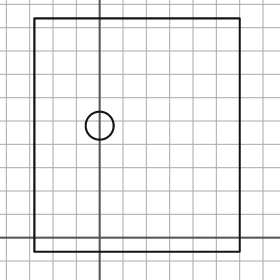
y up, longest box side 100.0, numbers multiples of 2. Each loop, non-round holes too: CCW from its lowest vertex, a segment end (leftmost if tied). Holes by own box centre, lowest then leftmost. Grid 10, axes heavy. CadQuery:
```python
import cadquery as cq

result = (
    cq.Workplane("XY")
    .moveTo(-28.0, -6.0)
    .lineTo(60.0, -6.0)
    .lineTo(60.0, 94.0)
    .lineTo(-28.0, 94.0)
    .close()
    .moveTo(0.0, 48.0)
    .circle(6.0)
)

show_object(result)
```